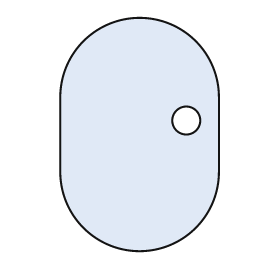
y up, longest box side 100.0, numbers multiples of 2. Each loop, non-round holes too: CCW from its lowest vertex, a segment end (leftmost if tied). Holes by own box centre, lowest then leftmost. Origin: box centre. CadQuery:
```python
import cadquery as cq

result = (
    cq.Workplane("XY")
    .moveTo(-34.0, -16.0)
    .threePointArc((0.0, -50.0), (34.0, -16.0))
    .lineTo(34.0, 16.0)
    .threePointArc((0.0, 50.0), (-34.0, 16.0))
    .close()
    .moveTo(20.0, 6.0)
    .circle(6.0)
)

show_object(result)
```